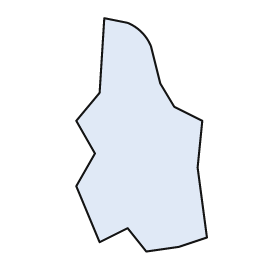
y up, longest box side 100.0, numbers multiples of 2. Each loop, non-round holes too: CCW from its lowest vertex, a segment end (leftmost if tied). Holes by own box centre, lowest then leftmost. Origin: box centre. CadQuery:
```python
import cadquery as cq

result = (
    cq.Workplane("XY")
    .moveTo(2.0, -50.0)
    .lineTo(16.0, -48.0)
    .lineTo(28.0, -44.0)
    .lineTo(24.0, -14.0)
    .lineTo(26.0, 6.0)
    .lineTo(14.0, 12.0)
    .lineTo(8.0, 22.0)
    .lineTo(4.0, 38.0)
    .threePointArc((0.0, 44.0), (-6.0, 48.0))
    .lineTo(-16.0, 50.0)
    .lineTo(-18.0, 18.0)
    .lineTo(-28.0, 6.0)
    .lineTo(-20.0, -8.0)
    .lineTo(-28.0, -22.0)
    .lineTo(-18.0, -46.0)
    .lineTo(-6.0, -40.0)
    .close()
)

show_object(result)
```